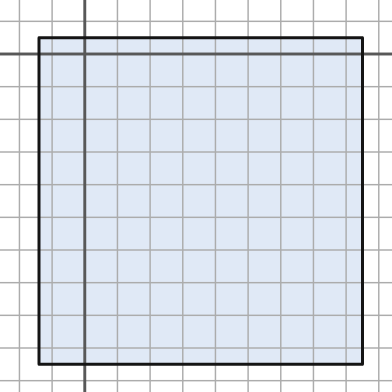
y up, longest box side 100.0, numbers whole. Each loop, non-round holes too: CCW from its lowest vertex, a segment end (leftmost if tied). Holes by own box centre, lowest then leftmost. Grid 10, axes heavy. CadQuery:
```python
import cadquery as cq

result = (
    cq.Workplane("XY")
    .moveTo(-14.0, -95.0)
    .lineTo(85.0, -95.0)
    .lineTo(85.0, 5.0)
    .lineTo(-14.0, 5.0)
    .close()
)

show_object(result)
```